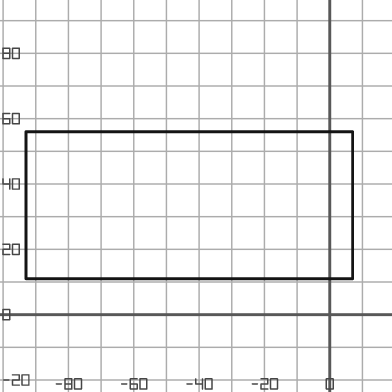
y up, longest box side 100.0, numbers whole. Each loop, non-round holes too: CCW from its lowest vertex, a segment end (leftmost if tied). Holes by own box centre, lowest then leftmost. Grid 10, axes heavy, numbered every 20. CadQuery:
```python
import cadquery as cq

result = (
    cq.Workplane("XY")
    .moveTo(-93.0, 11.0)
    .lineTo(7.0, 11.0)
    .lineTo(7.0, 56.0)
    .lineTo(-93.0, 56.0)
    .close()
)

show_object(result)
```